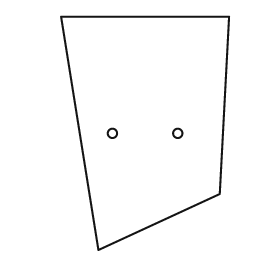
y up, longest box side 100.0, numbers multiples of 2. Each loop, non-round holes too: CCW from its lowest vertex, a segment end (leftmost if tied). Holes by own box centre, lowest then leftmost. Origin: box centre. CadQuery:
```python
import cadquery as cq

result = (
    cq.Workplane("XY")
    .moveTo(-20.0, -50.0)
    .lineTo(32.0, -26.0)
    .lineTo(36.0, 50.0)
    .lineTo(-36.0, 50.0)
    .close()
    .moveTo(-14.0, 0.0)
    .circle(2.0)
    .moveTo(14.0, 0.0)
    .circle(2.0)
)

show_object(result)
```